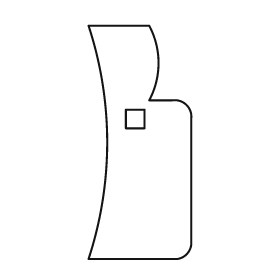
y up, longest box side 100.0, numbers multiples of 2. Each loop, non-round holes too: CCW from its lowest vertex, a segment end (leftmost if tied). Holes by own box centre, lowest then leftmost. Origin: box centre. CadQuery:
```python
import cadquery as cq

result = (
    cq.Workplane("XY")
    .moveTo(-22.0, -50.0)
    .lineTo(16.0, -50.0)
    .threePointArc((20.0, -48.0), (22.0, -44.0))
    .lineTo(22.0, 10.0)
    .threePointArc((20.0, 16.0), (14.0, 18.0))
    .lineTo(4.0, 18.0)
    .threePointArc((8.0, 34.0), (4.0, 50.0))
    .lineTo(-22.0, 50.0)
    .threePointArc((-14.0, 0.0), (-22.0, -50.0))
    .close()
    .moveTo(-6.0, 6.0)
    .lineTo(2.0, 6.0)
    .lineTo(2.0, 14.0)
    .lineTo(-6.0, 14.0)
    .close()
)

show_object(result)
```